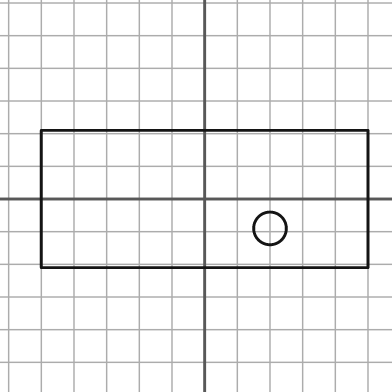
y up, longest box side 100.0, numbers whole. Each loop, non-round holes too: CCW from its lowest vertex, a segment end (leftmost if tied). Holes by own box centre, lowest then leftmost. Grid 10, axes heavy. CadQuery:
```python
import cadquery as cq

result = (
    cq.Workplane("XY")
    .moveTo(-50.0, -21.0)
    .lineTo(50.0, -21.0)
    .lineTo(50.0, 21.0)
    .lineTo(-50.0, 21.0)
    .close()
    .moveTo(20.0, -9.0)
    .circle(5.0)
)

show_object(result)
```